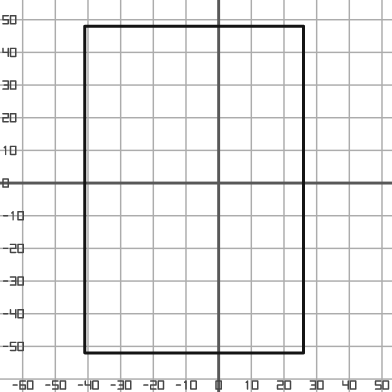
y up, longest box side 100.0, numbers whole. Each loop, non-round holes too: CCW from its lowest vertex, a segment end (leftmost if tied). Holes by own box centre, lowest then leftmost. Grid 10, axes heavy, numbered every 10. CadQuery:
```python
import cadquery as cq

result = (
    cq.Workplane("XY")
    .moveTo(-41.0, -52.0)
    .lineTo(26.0, -52.0)
    .lineTo(26.0, 48.0)
    .lineTo(-41.0, 48.0)
    .close()
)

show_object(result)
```